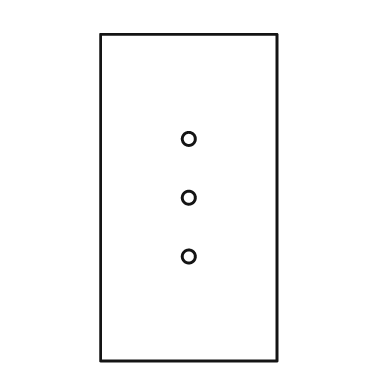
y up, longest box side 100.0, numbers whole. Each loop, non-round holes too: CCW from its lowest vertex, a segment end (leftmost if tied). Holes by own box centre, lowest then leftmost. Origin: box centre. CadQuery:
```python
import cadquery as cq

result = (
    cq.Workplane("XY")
    .moveTo(-27.0, -50.0)
    .lineTo(27.0, -50.0)
    .lineTo(27.0, 50.0)
    .lineTo(-27.0, 50.0)
    .close()
    .moveTo(0.0, -18.0)
    .circle(2.0)
    .moveTo(0.0, 0.0)
    .circle(2.0)
    .moveTo(0.0, 18.0)
    .circle(2.0)
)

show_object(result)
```